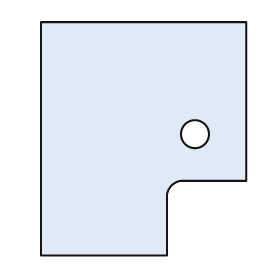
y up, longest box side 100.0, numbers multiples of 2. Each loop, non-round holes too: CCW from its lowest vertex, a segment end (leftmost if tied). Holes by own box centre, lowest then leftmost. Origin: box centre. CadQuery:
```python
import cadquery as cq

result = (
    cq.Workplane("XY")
    .moveTo(-44.0, -50.0)
    .lineTo(10.0, -50.0)
    .lineTo(10.0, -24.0)
    .threePointArc((12.0, -20.0), (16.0, -18.0))
    .lineTo(44.0, -18.0)
    .lineTo(44.0, 50.0)
    .lineTo(-44.0, 50.0)
    .close()
    .moveTo(22.0, 2.0)
    .circle(6.0)
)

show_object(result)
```